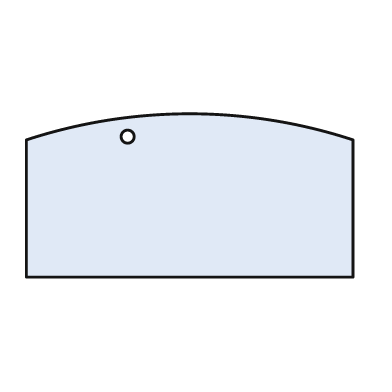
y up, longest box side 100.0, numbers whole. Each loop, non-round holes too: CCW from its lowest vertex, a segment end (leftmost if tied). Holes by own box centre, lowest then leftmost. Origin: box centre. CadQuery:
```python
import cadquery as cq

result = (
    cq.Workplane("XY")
    .moveTo(-50.0, -25.0)
    .lineTo(50.0, -25.0)
    .lineTo(50.0, 17.0)
    .threePointArc((0.0, 25.0), (-50.0, 17.0))
    .close()
    .moveTo(-19.0, 18.0)
    .circle(2.0)
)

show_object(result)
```